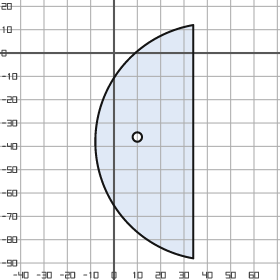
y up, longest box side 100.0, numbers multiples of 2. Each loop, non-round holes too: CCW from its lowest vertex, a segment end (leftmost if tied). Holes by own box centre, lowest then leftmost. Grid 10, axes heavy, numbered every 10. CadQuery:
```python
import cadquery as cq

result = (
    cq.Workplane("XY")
    .moveTo(34.0, -88.0)
    .lineTo(34.0, 12.0)
    .threePointArc((-8.0, -38.0), (34.0, -88.0))
    .close()
    .moveTo(10.0, -36.0)
    .circle(2.0)
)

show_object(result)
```